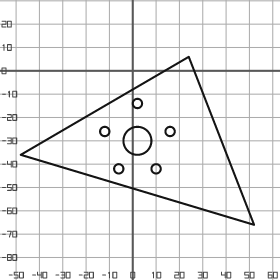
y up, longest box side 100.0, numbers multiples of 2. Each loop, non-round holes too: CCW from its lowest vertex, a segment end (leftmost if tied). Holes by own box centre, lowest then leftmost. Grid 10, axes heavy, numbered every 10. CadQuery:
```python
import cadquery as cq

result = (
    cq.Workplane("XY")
    .moveTo(52.0, -66.0)
    .lineTo(24.0, 6.0)
    .lineTo(-48.0, -36.0)
    .close()
    .moveTo(-6.0, -42.0)
    .circle(2.0)
    .moveTo(10.0, -42.0)
    .circle(2.0)
    .moveTo(2.0, -30.0)
    .circle(6.0)
    .moveTo(-12.0, -26.0)
    .circle(2.0)
    .moveTo(16.0, -26.0)
    .circle(2.0)
    .moveTo(2.0, -14.0)
    .circle(2.0)
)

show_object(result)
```